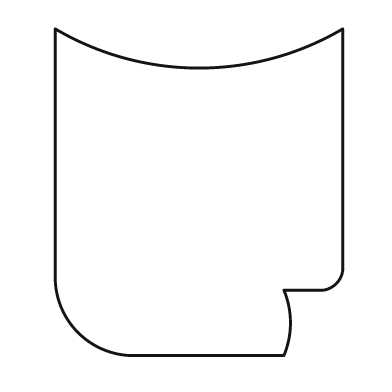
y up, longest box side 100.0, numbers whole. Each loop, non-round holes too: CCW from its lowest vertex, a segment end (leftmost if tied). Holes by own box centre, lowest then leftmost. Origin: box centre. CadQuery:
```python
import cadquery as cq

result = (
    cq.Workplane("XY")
    .moveTo(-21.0, -50.0)
    .lineTo(26.0, -50.0)
    .threePointArc((28.0, -40.0), (26.0, -30.0))
    .lineTo(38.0, -30.0)
    .threePointArc((42.0, -28.0), (44.0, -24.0))
    .lineTo(44.0, 50.0)
    .threePointArc((0.0, 38.0), (-44.0, 50.0))
    .lineTo(-44.0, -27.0)
    .threePointArc((-37.0, -43.0), (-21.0, -50.0))
    .close()
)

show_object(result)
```